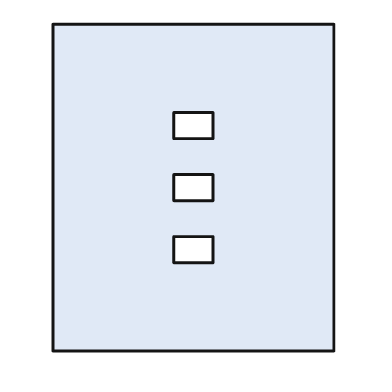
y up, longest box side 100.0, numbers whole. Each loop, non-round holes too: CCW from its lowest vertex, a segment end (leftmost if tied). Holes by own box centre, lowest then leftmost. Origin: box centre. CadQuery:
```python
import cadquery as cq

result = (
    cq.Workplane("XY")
    .moveTo(-43.0, -50.0)
    .lineTo(43.0, -50.0)
    .lineTo(43.0, 50.0)
    .lineTo(-43.0, 50.0)
    .close()
    .moveTo(-6.0, -23.0)
    .lineTo(6.0, -23.0)
    .lineTo(6.0, -15.0)
    .lineTo(-6.0, -15.0)
    .close()
    .moveTo(-6.0, -4.0)
    .lineTo(6.0, -4.0)
    .lineTo(6.0, 4.0)
    .lineTo(-6.0, 4.0)
    .close()
    .moveTo(-6.0, 15.0)
    .lineTo(6.0, 15.0)
    .lineTo(6.0, 23.0)
    .lineTo(-6.0, 23.0)
    .close()
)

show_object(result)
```